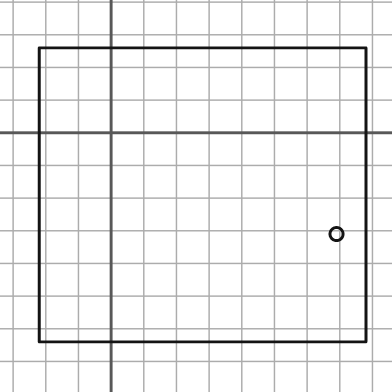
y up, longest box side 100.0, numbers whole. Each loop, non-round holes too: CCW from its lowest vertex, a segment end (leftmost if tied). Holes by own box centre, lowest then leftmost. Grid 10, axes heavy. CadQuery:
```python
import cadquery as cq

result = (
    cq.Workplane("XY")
    .moveTo(-22.0, -64.0)
    .lineTo(78.0, -64.0)
    .lineTo(78.0, 26.0)
    .lineTo(-22.0, 26.0)
    .close()
    .moveTo(69.0, -31.0)
    .circle(2.0)
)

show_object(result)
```